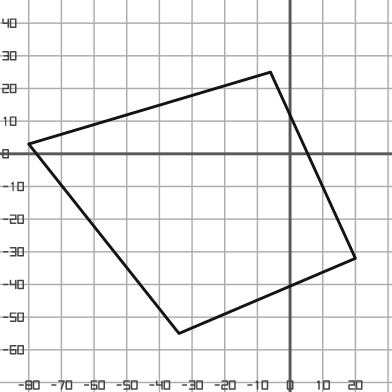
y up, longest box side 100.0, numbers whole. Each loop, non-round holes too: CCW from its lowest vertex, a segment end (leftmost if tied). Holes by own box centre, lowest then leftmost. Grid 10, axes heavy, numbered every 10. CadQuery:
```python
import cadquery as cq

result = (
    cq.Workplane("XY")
    .moveTo(-34.0, -55.0)
    .lineTo(20.0, -32.0)
    .lineTo(-6.0, 25.0)
    .lineTo(-80.0, 3.0)
    .close()
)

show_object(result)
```